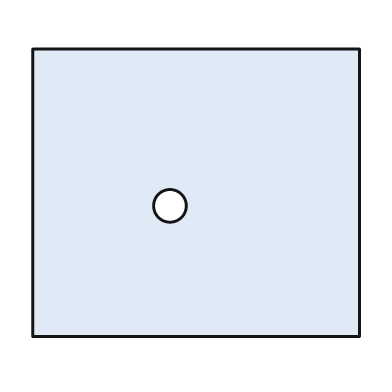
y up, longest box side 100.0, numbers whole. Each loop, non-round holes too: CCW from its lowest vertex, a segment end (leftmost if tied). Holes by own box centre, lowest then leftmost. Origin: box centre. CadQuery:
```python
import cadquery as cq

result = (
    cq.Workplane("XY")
    .moveTo(-50.0, -44.0)
    .lineTo(50.0, -44.0)
    .lineTo(50.0, 44.0)
    .lineTo(-50.0, 44.0)
    .close()
    .moveTo(-8.0, -4.0)
    .circle(5.0)
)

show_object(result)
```